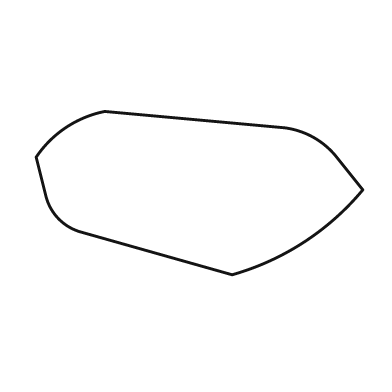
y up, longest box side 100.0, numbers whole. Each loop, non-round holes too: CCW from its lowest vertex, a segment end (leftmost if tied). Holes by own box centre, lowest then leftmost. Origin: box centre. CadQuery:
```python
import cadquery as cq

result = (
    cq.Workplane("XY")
    .moveTo(10.0, -25.0)
    .threePointArc((32.0, -15.0), (50.0, 1.0))
    .lineTo(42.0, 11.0)
    .threePointArc((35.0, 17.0), (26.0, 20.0))
    .lineTo(-29.0, 25.0)
    .threePointArc((-41.0, 20.0), (-50.0, 11.0))
    .lineTo(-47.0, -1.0)
    .threePointArc((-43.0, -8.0), (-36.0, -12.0))
    .close()
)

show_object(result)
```